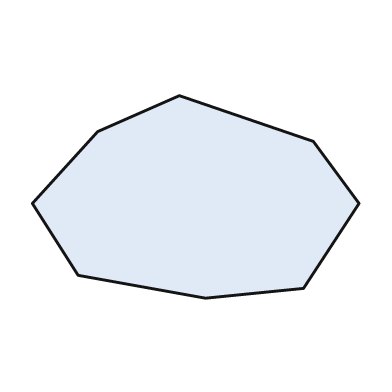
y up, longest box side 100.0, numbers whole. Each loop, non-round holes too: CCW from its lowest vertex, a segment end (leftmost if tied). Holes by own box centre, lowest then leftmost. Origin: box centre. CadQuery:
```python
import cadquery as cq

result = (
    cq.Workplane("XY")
    .moveTo(3.0, -31.0)
    .lineTo(33.0, -28.0)
    .lineTo(50.0, -2.0)
    .lineTo(36.0, 17.0)
    .lineTo(-5.0, 31.0)
    .lineTo(-30.0, 20.0)
    .lineTo(-50.0, -2.0)
    .lineTo(-36.0, -24.0)
    .close()
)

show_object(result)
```